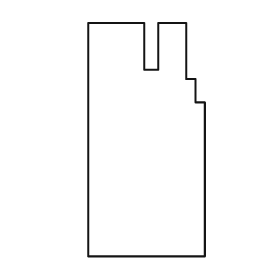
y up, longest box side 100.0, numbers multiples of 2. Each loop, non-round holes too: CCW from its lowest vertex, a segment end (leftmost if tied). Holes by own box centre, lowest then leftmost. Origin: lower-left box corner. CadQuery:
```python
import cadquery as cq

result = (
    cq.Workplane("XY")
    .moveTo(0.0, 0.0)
    .lineTo(50.0, 0.0)
    .lineTo(50.0, 66.0)
    .lineTo(46.0, 66.0)
    .lineTo(46.0, 76.0)
    .lineTo(42.0, 76.0)
    .lineTo(42.0, 100.0)
    .lineTo(30.0, 100.0)
    .lineTo(30.0, 80.0)
    .lineTo(24.0, 80.0)
    .lineTo(24.0, 100.0)
    .lineTo(0.0, 100.0)
    .close()
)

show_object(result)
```